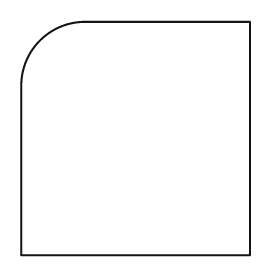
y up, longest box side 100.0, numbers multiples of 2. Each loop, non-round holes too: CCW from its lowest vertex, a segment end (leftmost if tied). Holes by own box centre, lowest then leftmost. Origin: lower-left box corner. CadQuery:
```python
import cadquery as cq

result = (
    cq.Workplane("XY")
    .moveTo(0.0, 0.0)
    .lineTo(98.0, 0.0)
    .lineTo(98.0, 100.0)
    .lineTo(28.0, 100.0)
    .threePointArc((8.0, 92.0), (0.0, 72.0))
    .close()
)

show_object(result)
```